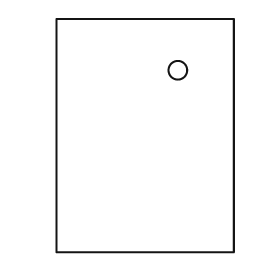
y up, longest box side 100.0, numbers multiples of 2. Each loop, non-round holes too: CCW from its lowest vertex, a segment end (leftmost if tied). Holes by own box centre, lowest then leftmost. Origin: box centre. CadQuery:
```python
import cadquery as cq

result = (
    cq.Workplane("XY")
    .moveTo(-38.0, -50.0)
    .lineTo(38.0, -50.0)
    .lineTo(38.0, 50.0)
    .lineTo(-38.0, 50.0)
    .close()
    .moveTo(14.0, 28.0)
    .circle(4.0)
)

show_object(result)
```